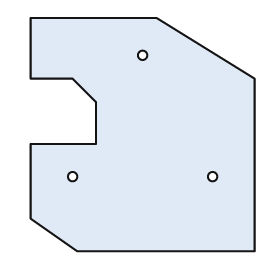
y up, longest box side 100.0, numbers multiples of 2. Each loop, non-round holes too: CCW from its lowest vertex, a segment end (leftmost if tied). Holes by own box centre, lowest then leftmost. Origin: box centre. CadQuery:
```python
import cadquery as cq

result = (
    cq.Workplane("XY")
    .moveTo(-28.0, -50.0)
    .lineTo(48.0, -50.0)
    .lineTo(48.0, 24.0)
    .lineTo(6.0, 50.0)
    .lineTo(-48.0, 50.0)
    .lineTo(-48.0, 24.0)
    .lineTo(-30.0, 24.0)
    .lineTo(-20.0, 14.0)
    .lineTo(-20.0, -4.0)
    .lineTo(-48.0, -4.0)
    .lineTo(-48.0, -36.0)
    .close()
    .moveTo(-30.0, -18.0)
    .circle(2.0)
    .moveTo(30.0, -18.0)
    .circle(2.0)
    .moveTo(0.0, 34.0)
    .circle(2.0)
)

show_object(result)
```